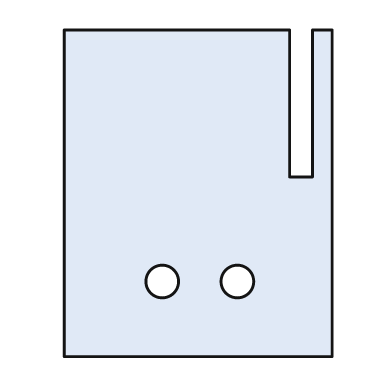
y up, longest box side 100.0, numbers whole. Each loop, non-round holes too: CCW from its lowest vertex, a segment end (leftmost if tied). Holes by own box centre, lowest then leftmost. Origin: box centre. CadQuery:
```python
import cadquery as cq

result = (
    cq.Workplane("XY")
    .moveTo(-41.0, -50.0)
    .lineTo(41.0, -50.0)
    .lineTo(41.0, 50.0)
    .lineTo(35.0, 50.0)
    .lineTo(35.0, 5.0)
    .lineTo(28.0, 5.0)
    .lineTo(28.0, 50.0)
    .lineTo(-41.0, 50.0)
    .close()
    .moveTo(-11.0, -27.0)
    .circle(5.0)
    .moveTo(12.0, -27.0)
    .circle(5.0)
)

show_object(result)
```